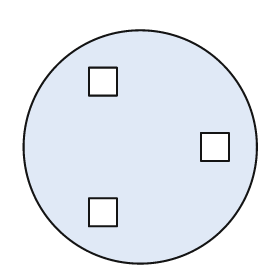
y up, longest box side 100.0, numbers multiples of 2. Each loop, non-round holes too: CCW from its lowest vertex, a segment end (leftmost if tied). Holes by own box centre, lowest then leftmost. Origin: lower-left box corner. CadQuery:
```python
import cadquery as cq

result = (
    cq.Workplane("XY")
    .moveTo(50.0, 50.0)
    .circle(50.0)
    .moveTo(28.0, 16.0)
    .lineTo(40.0, 16.0)
    .lineTo(40.0, 28.0)
    .lineTo(28.0, 28.0)
    .close()
    .moveTo(76.0, 44.0)
    .lineTo(88.0, 44.0)
    .lineTo(88.0, 56.0)
    .lineTo(76.0, 56.0)
    .close()
    .moveTo(28.0, 72.0)
    .lineTo(40.0, 72.0)
    .lineTo(40.0, 84.0)
    .lineTo(28.0, 84.0)
    .close()
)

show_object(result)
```